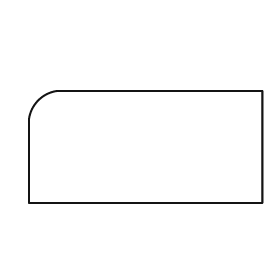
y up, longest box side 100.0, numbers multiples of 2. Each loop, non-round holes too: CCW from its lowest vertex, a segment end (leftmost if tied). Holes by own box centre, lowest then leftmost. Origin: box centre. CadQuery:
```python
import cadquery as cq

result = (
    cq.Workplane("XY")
    .moveTo(-50.0, -24.0)
    .lineTo(50.0, -24.0)
    .lineTo(50.0, 24.0)
    .lineTo(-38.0, 24.0)
    .threePointArc((-46.0, 20.0), (-50.0, 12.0))
    .close()
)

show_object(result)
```